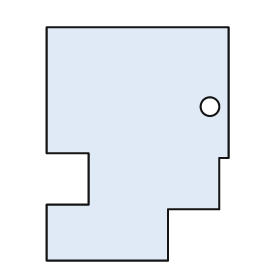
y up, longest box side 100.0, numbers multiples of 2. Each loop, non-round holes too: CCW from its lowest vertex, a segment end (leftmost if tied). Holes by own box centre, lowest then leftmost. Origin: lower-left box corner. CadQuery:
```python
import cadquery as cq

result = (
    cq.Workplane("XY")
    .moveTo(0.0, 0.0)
    .lineTo(52.0, 0.0)
    .lineTo(52.0, 22.0)
    .lineTo(74.0, 22.0)
    .lineTo(74.0, 44.0)
    .lineTo(78.0, 44.0)
    .lineTo(78.0, 100.0)
    .lineTo(0.0, 100.0)
    .lineTo(0.0, 46.0)
    .lineTo(18.0, 46.0)
    .lineTo(18.0, 24.0)
    .lineTo(0.0, 24.0)
    .close()
    .moveTo(70.0, 66.0)
    .circle(4.0)
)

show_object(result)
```